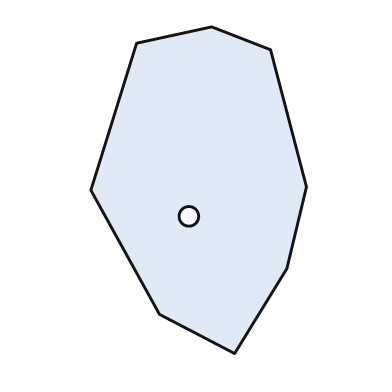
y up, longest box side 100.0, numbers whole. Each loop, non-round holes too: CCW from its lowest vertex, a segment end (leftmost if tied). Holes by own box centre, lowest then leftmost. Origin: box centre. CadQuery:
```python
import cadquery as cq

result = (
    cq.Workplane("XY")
    .moveTo(11.0, -50.0)
    .lineTo(27.0, -24.0)
    .lineTo(33.0, 1.0)
    .lineTo(22.0, 43.0)
    .lineTo(4.0, 50.0)
    .lineTo(-19.0, 45.0)
    .lineTo(-33.0, 0.0)
    .lineTo(-12.0, -38.0)
    .close()
    .moveTo(-3.0, -8.0)
    .circle(3.0)
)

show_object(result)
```